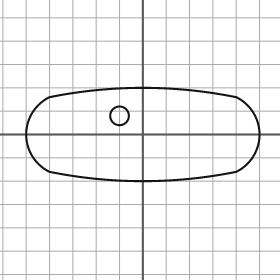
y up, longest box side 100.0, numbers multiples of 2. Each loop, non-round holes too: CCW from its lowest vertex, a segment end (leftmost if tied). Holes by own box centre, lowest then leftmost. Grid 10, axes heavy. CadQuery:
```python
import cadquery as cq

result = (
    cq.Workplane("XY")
    .moveTo(-40.0, -16.0)
    .threePointArc((0.0, -20.0), (40.0, -16.0))
    .threePointArc((50.0, 0.0), (40.0, 16.0))
    .threePointArc((0.0, 20.0), (-40.0, 16.0))
    .threePointArc((-50.0, 0.0), (-40.0, -16.0))
    .close()
    .moveTo(-10.0, 8.0)
    .circle(4.0)
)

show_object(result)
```